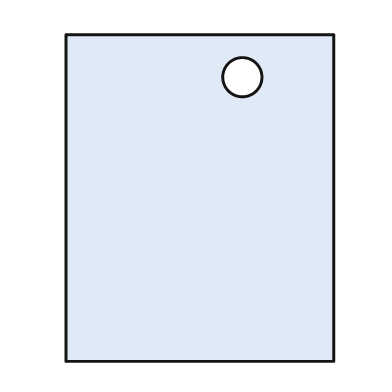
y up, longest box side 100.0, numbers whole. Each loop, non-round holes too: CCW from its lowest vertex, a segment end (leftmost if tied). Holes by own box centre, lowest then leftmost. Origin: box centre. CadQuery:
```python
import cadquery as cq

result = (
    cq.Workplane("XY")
    .moveTo(-41.0, -50.0)
    .lineTo(41.0, -50.0)
    .lineTo(41.0, 50.0)
    .lineTo(-41.0, 50.0)
    .close()
    .moveTo(13.0, 37.0)
    .circle(6.0)
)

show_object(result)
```